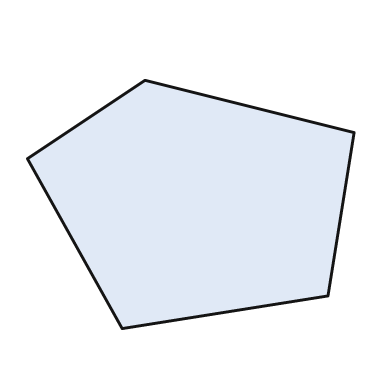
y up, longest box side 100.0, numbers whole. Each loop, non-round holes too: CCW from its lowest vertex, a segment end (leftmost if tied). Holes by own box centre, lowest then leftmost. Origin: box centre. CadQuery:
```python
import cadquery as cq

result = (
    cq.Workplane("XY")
    .moveTo(-21.0, -38.0)
    .lineTo(42.0, -28.0)
    .lineTo(50.0, 22.0)
    .lineTo(-14.0, 38.0)
    .lineTo(-50.0, 14.0)
    .close()
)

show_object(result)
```